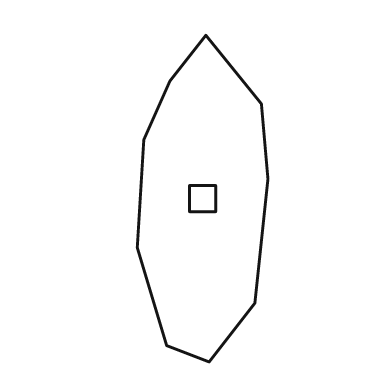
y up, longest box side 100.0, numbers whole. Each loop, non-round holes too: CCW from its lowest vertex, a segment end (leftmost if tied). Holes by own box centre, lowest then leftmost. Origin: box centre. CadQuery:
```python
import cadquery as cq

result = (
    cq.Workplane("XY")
    .moveTo(2.0, -50.0)
    .lineTo(16.0, -32.0)
    .lineTo(20.0, 6.0)
    .lineTo(18.0, 29.0)
    .lineTo(1.0, 50.0)
    .lineTo(-10.0, 36.0)
    .lineTo(-18.0, 18.0)
    .lineTo(-20.0, -15.0)
    .lineTo(-11.0, -45.0)
    .close()
    .moveTo(-4.0, -4.0)
    .lineTo(4.0, -4.0)
    .lineTo(4.0, 4.0)
    .lineTo(-4.0, 4.0)
    .close()
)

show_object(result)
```